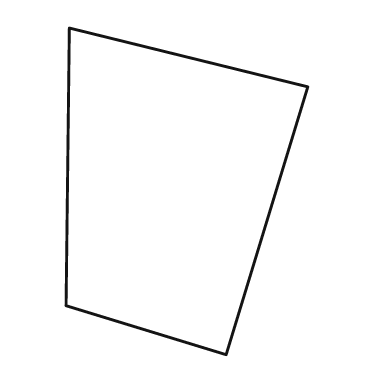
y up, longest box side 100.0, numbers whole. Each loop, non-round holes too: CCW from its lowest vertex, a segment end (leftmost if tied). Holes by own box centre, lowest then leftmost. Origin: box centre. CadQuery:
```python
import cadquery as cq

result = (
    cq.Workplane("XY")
    .moveTo(12.0, -50.0)
    .lineTo(37.0, 32.0)
    .lineTo(-36.0, 50.0)
    .lineTo(-37.0, -35.0)
    .close()
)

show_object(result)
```